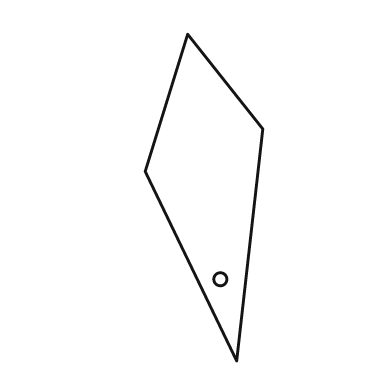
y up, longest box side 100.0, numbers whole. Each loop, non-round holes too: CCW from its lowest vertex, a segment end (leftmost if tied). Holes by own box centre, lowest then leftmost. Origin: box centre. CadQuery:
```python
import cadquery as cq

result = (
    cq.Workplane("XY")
    .moveTo(10.0, -50.0)
    .lineTo(18.0, 21.0)
    .lineTo(-5.0, 50.0)
    .lineTo(-18.0, 8.0)
    .close()
    .moveTo(5.0, -25.0)
    .circle(2.0)
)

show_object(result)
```